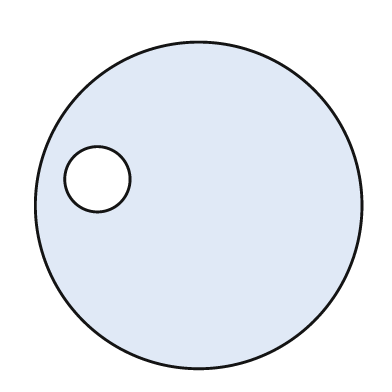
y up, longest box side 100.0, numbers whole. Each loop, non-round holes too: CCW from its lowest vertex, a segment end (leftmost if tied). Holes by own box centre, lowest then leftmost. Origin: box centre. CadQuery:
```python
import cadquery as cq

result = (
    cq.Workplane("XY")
    .moveTo(0.0, 0.0)
    .circle(50.0)
    .moveTo(-31.0, 8.0)
    .circle(10.0)
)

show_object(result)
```